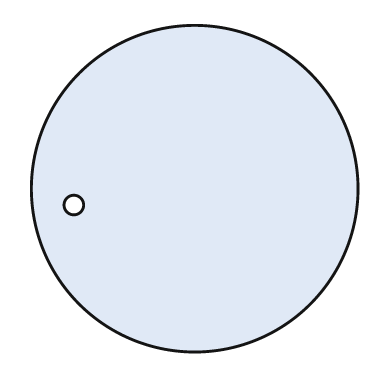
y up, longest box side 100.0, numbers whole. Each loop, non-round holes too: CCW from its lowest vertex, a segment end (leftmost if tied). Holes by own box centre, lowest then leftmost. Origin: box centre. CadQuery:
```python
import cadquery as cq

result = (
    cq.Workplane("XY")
    .moveTo(0.0, 0.0)
    .circle(50.0)
    .moveTo(-37.0, -5.0)
    .circle(3.0)
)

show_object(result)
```